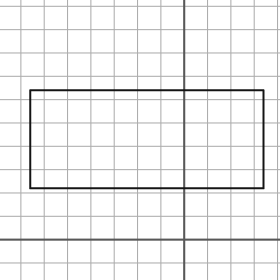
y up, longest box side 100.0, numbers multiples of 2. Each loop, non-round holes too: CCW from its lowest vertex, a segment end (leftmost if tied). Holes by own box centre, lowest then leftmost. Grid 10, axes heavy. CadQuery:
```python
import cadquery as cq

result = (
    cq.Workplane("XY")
    .moveTo(-66.0, 22.0)
    .lineTo(34.0, 22.0)
    .lineTo(34.0, 64.0)
    .lineTo(-66.0, 64.0)
    .close()
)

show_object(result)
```